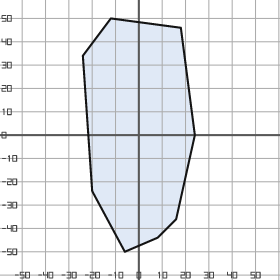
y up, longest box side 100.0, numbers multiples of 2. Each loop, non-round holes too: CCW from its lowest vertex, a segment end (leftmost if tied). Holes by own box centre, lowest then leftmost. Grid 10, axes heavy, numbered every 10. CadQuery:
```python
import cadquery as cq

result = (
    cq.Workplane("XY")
    .moveTo(-6.0, -50.0)
    .lineTo(8.0, -44.0)
    .lineTo(16.0, -36.0)
    .lineTo(24.0, 0.0)
    .lineTo(18.0, 46.0)
    .lineTo(-12.0, 50.0)
    .lineTo(-24.0, 34.0)
    .lineTo(-20.0, -24.0)
    .close()
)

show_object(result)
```